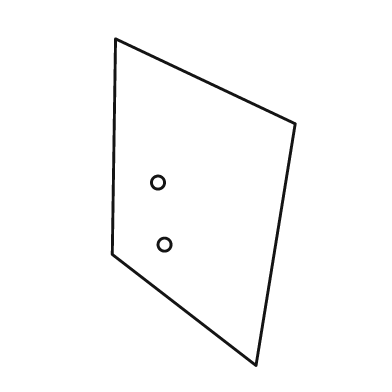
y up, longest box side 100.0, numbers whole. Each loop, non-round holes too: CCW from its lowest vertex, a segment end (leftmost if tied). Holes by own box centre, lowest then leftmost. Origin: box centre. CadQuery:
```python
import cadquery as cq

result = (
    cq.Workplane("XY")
    .moveTo(16.0, -50.0)
    .lineTo(28.0, 24.0)
    .lineTo(-27.0, 50.0)
    .lineTo(-28.0, -16.0)
    .close()
    .moveTo(-12.0, -13.0)
    .circle(2.0)
    .moveTo(-14.0, 6.0)
    .circle(2.0)
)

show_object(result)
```